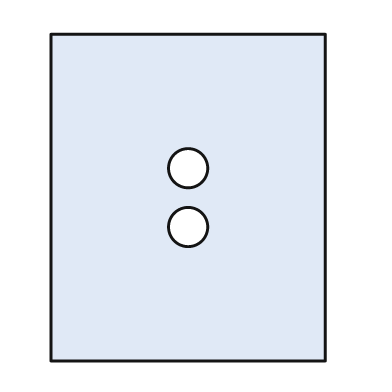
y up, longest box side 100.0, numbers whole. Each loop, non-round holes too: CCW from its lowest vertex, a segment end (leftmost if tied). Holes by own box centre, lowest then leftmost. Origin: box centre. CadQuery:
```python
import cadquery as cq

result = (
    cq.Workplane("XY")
    .moveTo(-42.0, -50.0)
    .lineTo(42.0, -50.0)
    .lineTo(42.0, 50.0)
    .lineTo(-42.0, 50.0)
    .close()
    .moveTo(0.0, -9.0)
    .circle(6.0)
    .moveTo(0.0, 9.0)
    .circle(6.0)
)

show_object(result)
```